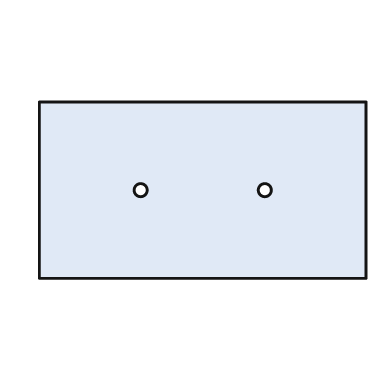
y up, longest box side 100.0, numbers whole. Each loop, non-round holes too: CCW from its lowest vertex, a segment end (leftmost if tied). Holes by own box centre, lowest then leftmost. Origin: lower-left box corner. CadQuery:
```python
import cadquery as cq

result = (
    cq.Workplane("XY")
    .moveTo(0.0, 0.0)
    .lineTo(100.0, 0.0)
    .lineTo(100.0, 54.0)
    .lineTo(0.0, 54.0)
    .close()
    .moveTo(31.0, 27.0)
    .circle(2.0)
    .moveTo(69.0, 27.0)
    .circle(2.0)
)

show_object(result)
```